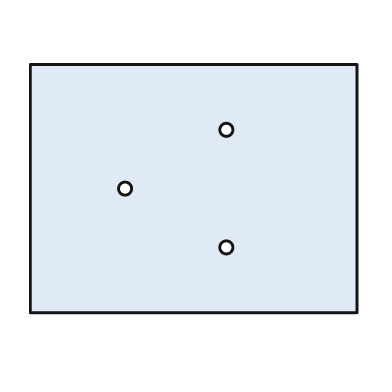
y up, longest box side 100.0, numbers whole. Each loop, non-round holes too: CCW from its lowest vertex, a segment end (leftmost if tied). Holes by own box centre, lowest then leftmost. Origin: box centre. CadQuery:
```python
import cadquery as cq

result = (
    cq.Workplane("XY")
    .moveTo(-50.0, -38.0)
    .lineTo(50.0, -38.0)
    .lineTo(50.0, 38.0)
    .lineTo(-50.0, 38.0)
    .close()
    .moveTo(10.0, -18.0)
    .circle(2.0)
    .moveTo(-21.0, 0.0)
    .circle(2.0)
    .moveTo(10.0, 18.0)
    .circle(2.0)
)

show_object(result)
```